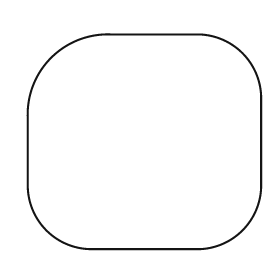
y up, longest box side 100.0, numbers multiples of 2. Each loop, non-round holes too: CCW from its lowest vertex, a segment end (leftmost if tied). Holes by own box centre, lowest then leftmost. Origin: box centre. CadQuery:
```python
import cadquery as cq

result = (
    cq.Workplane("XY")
    .moveTo(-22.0, -46.0)
    .lineTo(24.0, -46.0)
    .threePointArc((42.0, -38.0), (50.0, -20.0))
    .lineTo(50.0, 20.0)
    .threePointArc((42.0, 38.0), (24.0, 46.0))
    .lineTo(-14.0, 46.0)
    .threePointArc((-40.0, 36.0), (-50.0, 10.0))
    .lineTo(-50.0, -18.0)
    .threePointArc((-42.0, -38.0), (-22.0, -46.0))
    .close()
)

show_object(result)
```